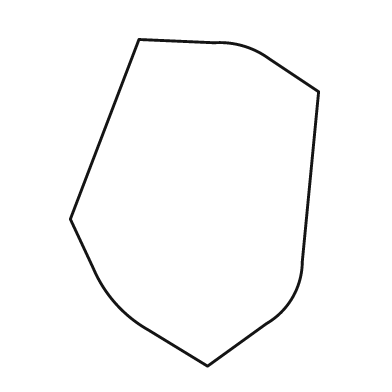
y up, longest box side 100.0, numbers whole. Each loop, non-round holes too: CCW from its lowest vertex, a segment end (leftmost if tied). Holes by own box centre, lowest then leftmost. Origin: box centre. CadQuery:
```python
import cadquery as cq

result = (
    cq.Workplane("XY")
    .moveTo(4.0, -50.0)
    .lineTo(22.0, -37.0)
    .threePointArc((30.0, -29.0), (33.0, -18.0))
    .lineTo(38.0, 34.0)
    .lineTo(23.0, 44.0)
    .threePointArc((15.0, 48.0), (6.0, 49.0))
    .lineTo(-17.0, 50.0)
    .lineTo(-38.0, -5.0)
    .lineTo(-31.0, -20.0)
    .threePointArc((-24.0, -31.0), (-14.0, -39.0))
    .close()
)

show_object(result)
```